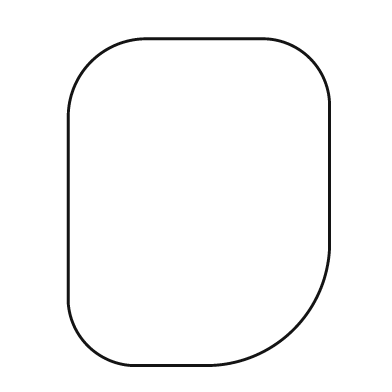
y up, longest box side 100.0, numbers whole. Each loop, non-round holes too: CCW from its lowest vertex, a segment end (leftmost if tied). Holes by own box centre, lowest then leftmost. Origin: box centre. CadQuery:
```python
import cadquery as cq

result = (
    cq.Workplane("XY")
    .moveTo(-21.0, -50.0)
    .lineTo(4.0, -50.0)
    .threePointArc((29.0, -39.0), (40.0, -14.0))
    .lineTo(40.0, 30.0)
    .threePointArc((34.0, 44.0), (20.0, 50.0))
    .lineTo(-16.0, 50.0)
    .threePointArc((-33.0, 43.0), (-40.0, 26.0))
    .lineTo(-40.0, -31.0)
    .threePointArc((-34.0, -44.0), (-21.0, -50.0))
    .close()
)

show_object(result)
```